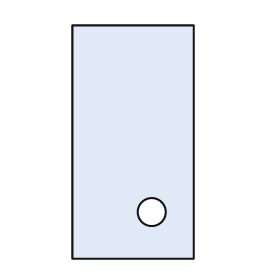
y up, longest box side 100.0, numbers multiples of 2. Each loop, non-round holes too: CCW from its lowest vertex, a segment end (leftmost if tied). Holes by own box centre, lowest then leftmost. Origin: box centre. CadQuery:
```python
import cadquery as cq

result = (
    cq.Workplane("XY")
    .moveTo(-26.0, -50.0)
    .lineTo(26.0, -50.0)
    .lineTo(26.0, 50.0)
    .lineTo(-26.0, 50.0)
    .close()
    .moveTo(8.0, -30.0)
    .circle(6.0)
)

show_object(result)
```